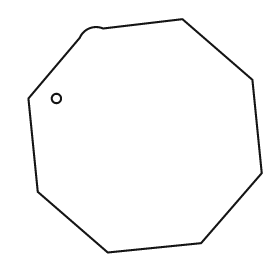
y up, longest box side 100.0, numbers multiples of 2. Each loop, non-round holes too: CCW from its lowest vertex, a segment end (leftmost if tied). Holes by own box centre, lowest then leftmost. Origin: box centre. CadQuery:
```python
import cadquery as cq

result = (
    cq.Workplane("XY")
    .moveTo(-16.0, -50.0)
    .lineTo(24.0, -46.0)
    .lineTo(50.0, -16.0)
    .lineTo(46.0, 24.0)
    .lineTo(16.0, 50.0)
    .lineTo(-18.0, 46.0)
    .threePointArc((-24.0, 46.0), (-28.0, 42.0))
    .lineTo(-50.0, 16.0)
    .lineTo(-46.0, -24.0)
    .close()
    .moveTo(-38.0, 16.0)
    .circle(2.0)
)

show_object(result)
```